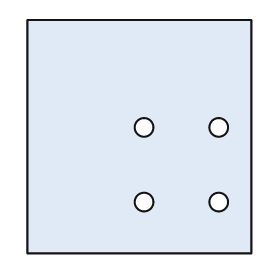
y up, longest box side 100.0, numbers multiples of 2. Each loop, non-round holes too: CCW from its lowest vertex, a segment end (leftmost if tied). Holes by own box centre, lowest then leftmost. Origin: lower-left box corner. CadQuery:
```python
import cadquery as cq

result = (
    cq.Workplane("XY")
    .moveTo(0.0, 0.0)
    .lineTo(96.0, 0.0)
    .lineTo(96.0, 100.0)
    .lineTo(0.0, 100.0)
    .close()
    .moveTo(50.0, 22.0)
    .circle(4.0)
    .moveTo(82.0, 22.0)
    .circle(4.0)
    .moveTo(50.0, 54.0)
    .circle(4.0)
    .moveTo(82.0, 54.0)
    .circle(4.0)
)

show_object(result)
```